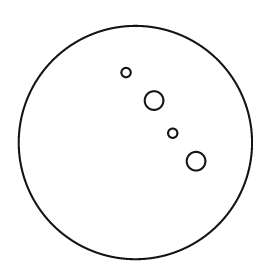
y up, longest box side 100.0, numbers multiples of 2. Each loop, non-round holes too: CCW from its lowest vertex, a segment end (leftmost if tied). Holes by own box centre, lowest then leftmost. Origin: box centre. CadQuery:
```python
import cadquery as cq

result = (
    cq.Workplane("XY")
    .moveTo(0.0, 0.0)
    .circle(50.0)
    .moveTo(26.0, -8.0)
    .circle(4.0)
    .moveTo(16.0, 4.0)
    .circle(2.0)
    .moveTo(8.0, 18.0)
    .circle(4.0)
    .moveTo(-4.0, 30.0)
    .circle(2.0)
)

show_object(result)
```